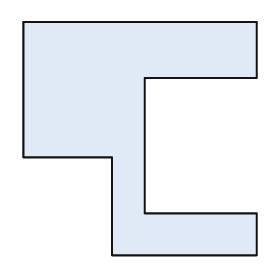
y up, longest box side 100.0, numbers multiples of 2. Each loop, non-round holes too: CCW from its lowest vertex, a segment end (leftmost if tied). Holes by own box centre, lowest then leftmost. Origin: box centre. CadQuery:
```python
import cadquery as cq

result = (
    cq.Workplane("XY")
    .moveTo(-12.0, -50.0)
    .lineTo(50.0, -50.0)
    .lineTo(50.0, -32.0)
    .lineTo(2.0, -32.0)
    .lineTo(2.0, 26.0)
    .lineTo(50.0, 26.0)
    .lineTo(50.0, 50.0)
    .lineTo(-50.0, 50.0)
    .lineTo(-50.0, -8.0)
    .lineTo(-12.0, -8.0)
    .close()
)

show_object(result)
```